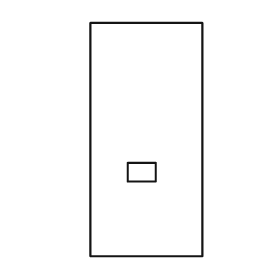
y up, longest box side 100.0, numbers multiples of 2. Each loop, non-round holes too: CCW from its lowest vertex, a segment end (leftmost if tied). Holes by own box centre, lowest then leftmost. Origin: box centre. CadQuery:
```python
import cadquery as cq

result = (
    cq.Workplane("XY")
    .moveTo(-24.0, -50.0)
    .lineTo(24.0, -50.0)
    .lineTo(24.0, 50.0)
    .lineTo(-24.0, 50.0)
    .close()
    .moveTo(-8.0, -18.0)
    .lineTo(4.0, -18.0)
    .lineTo(4.0, -10.0)
    .lineTo(-8.0, -10.0)
    .close()
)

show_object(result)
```